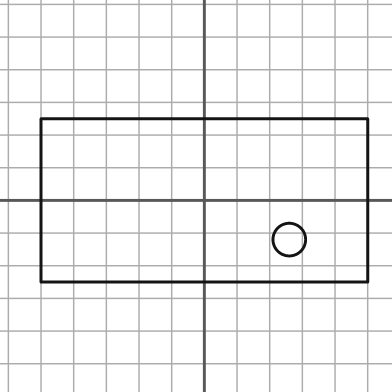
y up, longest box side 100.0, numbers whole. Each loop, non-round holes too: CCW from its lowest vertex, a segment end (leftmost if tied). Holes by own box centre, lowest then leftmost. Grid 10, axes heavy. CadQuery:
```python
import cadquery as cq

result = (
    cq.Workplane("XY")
    .moveTo(-50.0, -25.0)
    .lineTo(50.0, -25.0)
    .lineTo(50.0, 25.0)
    .lineTo(-50.0, 25.0)
    .close()
    .moveTo(26.0, -12.0)
    .circle(5.0)
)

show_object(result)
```